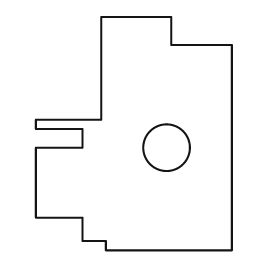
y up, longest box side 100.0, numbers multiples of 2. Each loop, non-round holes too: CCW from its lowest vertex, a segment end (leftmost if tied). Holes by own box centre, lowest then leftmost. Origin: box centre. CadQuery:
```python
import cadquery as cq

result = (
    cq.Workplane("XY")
    .moveTo(-12.0, -50.0)
    .lineTo(42.0, -50.0)
    .lineTo(42.0, 38.0)
    .lineTo(16.0, 38.0)
    .lineTo(16.0, 50.0)
    .lineTo(-14.0, 50.0)
    .lineTo(-14.0, 6.0)
    .lineTo(-42.0, 6.0)
    .lineTo(-42.0, 2.0)
    .lineTo(-22.0, 2.0)
    .lineTo(-22.0, -6.0)
    .lineTo(-42.0, -6.0)
    .lineTo(-42.0, -36.0)
    .lineTo(-22.0, -36.0)
    .lineTo(-22.0, -46.0)
    .lineTo(-12.0, -46.0)
    .close()
    .moveTo(14.0, -6.0)
    .circle(10.0)
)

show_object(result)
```